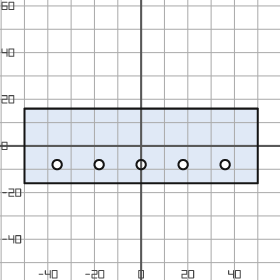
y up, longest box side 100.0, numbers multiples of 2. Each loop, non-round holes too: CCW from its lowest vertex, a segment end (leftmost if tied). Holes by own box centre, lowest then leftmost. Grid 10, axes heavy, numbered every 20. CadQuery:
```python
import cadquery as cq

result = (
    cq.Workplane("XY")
    .moveTo(-50.0, -16.0)
    .lineTo(50.0, -16.0)
    .lineTo(50.0, 16.0)
    .lineTo(-50.0, 16.0)
    .close()
    .moveTo(-36.0, -8.0)
    .circle(2.0)
    .moveTo(-18.0, -8.0)
    .circle(2.0)
    .moveTo(0.0, -8.0)
    .circle(2.0)
    .moveTo(18.0, -8.0)
    .circle(2.0)
    .moveTo(36.0, -8.0)
    .circle(2.0)
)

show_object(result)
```